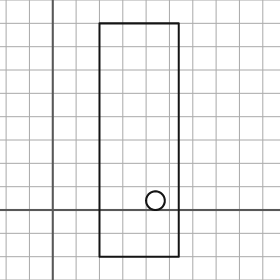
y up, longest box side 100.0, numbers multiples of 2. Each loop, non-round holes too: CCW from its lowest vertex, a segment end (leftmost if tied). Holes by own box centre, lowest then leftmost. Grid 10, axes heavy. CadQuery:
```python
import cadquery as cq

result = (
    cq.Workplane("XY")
    .moveTo(20.0, -20.0)
    .lineTo(54.0, -20.0)
    .lineTo(54.0, 80.0)
    .lineTo(20.0, 80.0)
    .close()
    .moveTo(44.0, 4.0)
    .circle(4.0)
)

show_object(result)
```